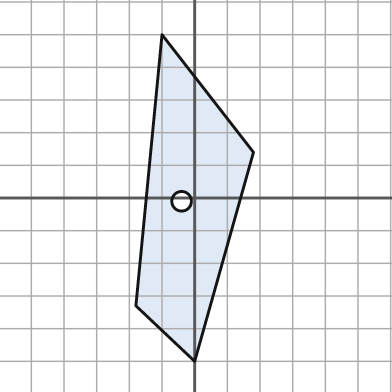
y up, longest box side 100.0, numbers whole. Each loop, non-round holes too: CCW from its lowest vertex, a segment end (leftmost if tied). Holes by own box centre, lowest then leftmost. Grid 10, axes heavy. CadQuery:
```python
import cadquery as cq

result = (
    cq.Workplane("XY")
    .moveTo(0.0, -50.0)
    .lineTo(18.0, 14.0)
    .lineTo(-10.0, 50.0)
    .lineTo(-18.0, -33.0)
    .close()
    .moveTo(-4.0, -1.0)
    .circle(3.0)
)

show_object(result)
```